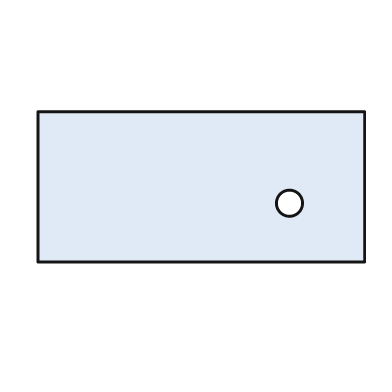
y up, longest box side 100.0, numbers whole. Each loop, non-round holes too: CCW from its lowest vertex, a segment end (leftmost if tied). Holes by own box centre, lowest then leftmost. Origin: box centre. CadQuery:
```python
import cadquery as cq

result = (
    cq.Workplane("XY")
    .moveTo(-50.0, -23.0)
    .lineTo(50.0, -23.0)
    .lineTo(50.0, 23.0)
    .lineTo(-50.0, 23.0)
    .close()
    .moveTo(27.0, -5.0)
    .circle(4.0)
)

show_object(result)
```